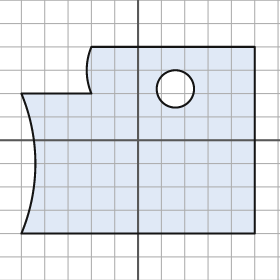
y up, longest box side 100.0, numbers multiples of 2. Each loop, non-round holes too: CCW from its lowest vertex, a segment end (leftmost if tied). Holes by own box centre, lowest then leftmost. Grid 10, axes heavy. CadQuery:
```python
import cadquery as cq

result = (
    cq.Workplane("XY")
    .moveTo(-50.0, -40.0)
    .lineTo(50.0, -40.0)
    .lineTo(50.0, 40.0)
    .lineTo(-20.0, 40.0)
    .threePointArc((-22.0, 30.0), (-20.0, 20.0))
    .lineTo(-50.0, 20.0)
    .threePointArc((-44.0, -10.0), (-50.0, -40.0))
    .close()
    .moveTo(16.0, 22.0)
    .circle(8.0)
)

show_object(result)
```